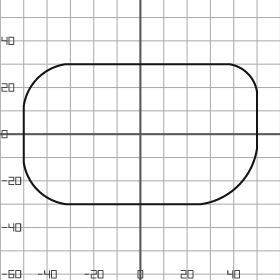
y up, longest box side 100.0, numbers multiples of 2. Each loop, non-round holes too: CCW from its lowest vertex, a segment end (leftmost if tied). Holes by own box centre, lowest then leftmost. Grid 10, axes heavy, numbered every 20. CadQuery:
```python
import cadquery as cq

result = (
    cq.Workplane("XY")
    .moveTo(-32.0, -30.0)
    .lineTo(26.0, -30.0)
    .threePointArc((42.0, -22.0), (50.0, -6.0))
    .lineTo(50.0, 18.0)
    .threePointArc((46.0, 26.0), (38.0, 30.0))
    .lineTo(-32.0, 30.0)
    .threePointArc((-44.0, 24.0), (-50.0, 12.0))
    .lineTo(-50.0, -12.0)
    .threePointArc((-44.0, -24.0), (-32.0, -30.0))
    .close()
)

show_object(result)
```